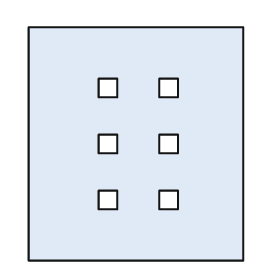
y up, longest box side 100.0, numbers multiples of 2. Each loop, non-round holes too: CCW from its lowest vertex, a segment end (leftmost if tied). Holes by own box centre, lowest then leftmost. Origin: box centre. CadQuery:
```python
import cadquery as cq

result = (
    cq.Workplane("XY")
    .moveTo(-46.0, -50.0)
    .lineTo(46.0, -50.0)
    .lineTo(46.0, 50.0)
    .lineTo(-46.0, 50.0)
    .close()
    .moveTo(-16.0, -28.0)
    .lineTo(-8.0, -28.0)
    .lineTo(-8.0, -20.0)
    .lineTo(-16.0, -20.0)
    .close()
    .moveTo(10.0, -28.0)
    .lineTo(18.0, -28.0)
    .lineTo(18.0, -20.0)
    .lineTo(10.0, -20.0)
    .close()
    .moveTo(-16.0, -4.0)
    .lineTo(-8.0, -4.0)
    .lineTo(-8.0, 4.0)
    .lineTo(-16.0, 4.0)
    .close()
    .moveTo(10.0, -4.0)
    .lineTo(18.0, -4.0)
    .lineTo(18.0, 4.0)
    .lineTo(10.0, 4.0)
    .close()
    .moveTo(-16.0, 20.0)
    .lineTo(-8.0, 20.0)
    .lineTo(-8.0, 28.0)
    .lineTo(-16.0, 28.0)
    .close()
    .moveTo(10.0, 20.0)
    .lineTo(18.0, 20.0)
    .lineTo(18.0, 28.0)
    .lineTo(10.0, 28.0)
    .close()
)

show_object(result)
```